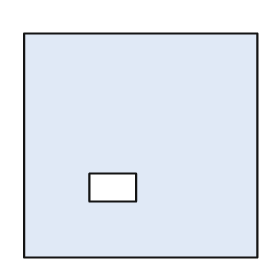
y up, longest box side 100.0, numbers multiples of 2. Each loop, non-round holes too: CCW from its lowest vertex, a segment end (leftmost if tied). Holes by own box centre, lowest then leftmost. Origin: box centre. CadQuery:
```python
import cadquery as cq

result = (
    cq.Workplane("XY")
    .moveTo(-50.0, -48.0)
    .lineTo(50.0, -48.0)
    .lineTo(50.0, 48.0)
    .lineTo(-50.0, 48.0)
    .close()
    .moveTo(-22.0, -24.0)
    .lineTo(-2.0, -24.0)
    .lineTo(-2.0, -12.0)
    .lineTo(-22.0, -12.0)
    .close()
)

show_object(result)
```